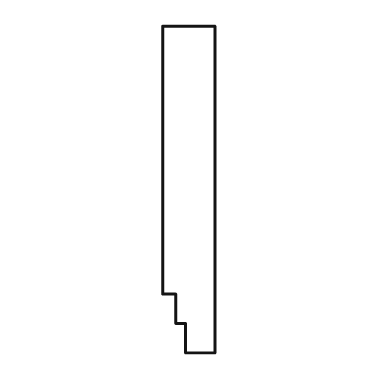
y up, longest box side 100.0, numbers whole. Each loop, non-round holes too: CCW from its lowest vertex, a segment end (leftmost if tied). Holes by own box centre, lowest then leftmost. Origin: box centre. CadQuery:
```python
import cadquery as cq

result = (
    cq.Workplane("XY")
    .moveTo(-1.0, -50.0)
    .lineTo(8.0, -50.0)
    .lineTo(8.0, 50.0)
    .lineTo(-8.0, 50.0)
    .lineTo(-8.0, -32.0)
    .lineTo(-4.0, -32.0)
    .lineTo(-4.0, -41.0)
    .lineTo(-1.0, -41.0)
    .close()
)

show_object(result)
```